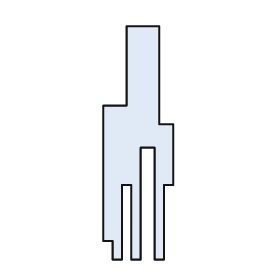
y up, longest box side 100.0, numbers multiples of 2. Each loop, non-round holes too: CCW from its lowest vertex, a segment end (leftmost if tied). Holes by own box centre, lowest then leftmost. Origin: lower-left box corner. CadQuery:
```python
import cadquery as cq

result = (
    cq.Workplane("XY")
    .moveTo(4.0, 0.0)
    .lineTo(8.0, 0.0)
    .lineTo(8.0, 32.0)
    .lineTo(12.0, 32.0)
    .lineTo(12.0, 0.0)
    .lineTo(16.0, 0.0)
    .lineTo(16.0, 48.0)
    .lineTo(22.0, 48.0)
    .lineTo(22.0, 0.0)
    .lineTo(26.0, 0.0)
    .lineTo(26.0, 32.0)
    .lineTo(30.0, 32.0)
    .lineTo(30.0, 58.0)
    .lineTo(24.0, 58.0)
    .lineTo(24.0, 100.0)
    .lineTo(10.0, 100.0)
    .lineTo(10.0, 66.0)
    .lineTo(0.0, 66.0)
    .lineTo(0.0, 8.0)
    .lineTo(4.0, 8.0)
    .close()
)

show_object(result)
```